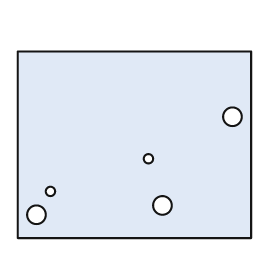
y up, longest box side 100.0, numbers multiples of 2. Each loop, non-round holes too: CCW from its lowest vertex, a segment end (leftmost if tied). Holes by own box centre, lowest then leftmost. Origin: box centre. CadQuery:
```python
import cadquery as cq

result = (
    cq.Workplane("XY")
    .moveTo(-50.0, -40.0)
    .lineTo(50.0, -40.0)
    .lineTo(50.0, 40.0)
    .lineTo(-50.0, 40.0)
    .close()
    .moveTo(-42.0, -30.0)
    .circle(4.0)
    .moveTo(12.0, -26.0)
    .circle(4.0)
    .moveTo(-36.0, -20.0)
    .circle(2.0)
    .moveTo(6.0, -6.0)
    .circle(2.0)
    .moveTo(42.0, 12.0)
    .circle(4.0)
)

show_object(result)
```